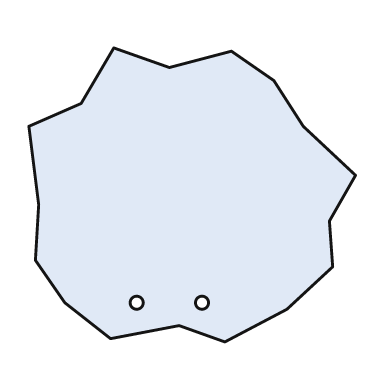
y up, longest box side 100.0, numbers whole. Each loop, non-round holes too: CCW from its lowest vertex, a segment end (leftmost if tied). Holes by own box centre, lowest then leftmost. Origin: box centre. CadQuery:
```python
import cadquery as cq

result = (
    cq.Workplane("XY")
    .moveTo(10.0, -45.0)
    .lineTo(29.0, -35.0)
    .lineTo(43.0, -22.0)
    .lineTo(42.0, -8.0)
    .lineTo(50.0, 6.0)
    .lineTo(34.0, 21.0)
    .lineTo(25.0, 35.0)
    .lineTo(12.0, 44.0)
    .lineTo(-7.0, 39.0)
    .lineTo(-24.0, 45.0)
    .lineTo(-34.0, 28.0)
    .lineTo(-50.0, 21.0)
    .lineTo(-47.0, -3.0)
    .lineTo(-48.0, -20.0)
    .lineTo(-39.0, -33.0)
    .lineTo(-25.0, -44.0)
    .lineTo(-4.0, -40.0)
    .close()
    .moveTo(-17.0, -33.0)
    .circle(2.0)
    .moveTo(3.0, -33.0)
    .circle(2.0)
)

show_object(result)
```